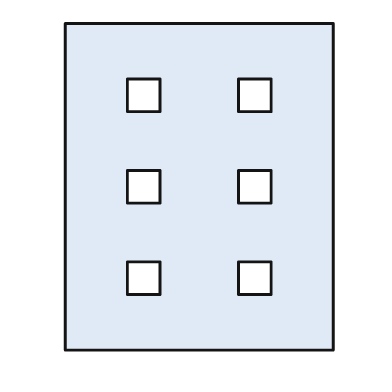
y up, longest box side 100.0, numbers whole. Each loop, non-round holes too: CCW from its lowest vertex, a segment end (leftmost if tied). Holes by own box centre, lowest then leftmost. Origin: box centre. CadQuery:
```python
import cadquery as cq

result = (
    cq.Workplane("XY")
    .moveTo(-41.0, -50.0)
    .lineTo(41.0, -50.0)
    .lineTo(41.0, 50.0)
    .lineTo(-41.0, 50.0)
    .close()
    .moveTo(-22.0, -33.0)
    .lineTo(-12.0, -33.0)
    .lineTo(-12.0, -23.0)
    .lineTo(-22.0, -23.0)
    .close()
    .moveTo(12.0, -33.0)
    .lineTo(22.0, -33.0)
    .lineTo(22.0, -23.0)
    .lineTo(12.0, -23.0)
    .close()
    .moveTo(-22.0, -5.0)
    .lineTo(-12.0, -5.0)
    .lineTo(-12.0, 5.0)
    .lineTo(-22.0, 5.0)
    .close()
    .moveTo(12.0, -5.0)
    .lineTo(22.0, -5.0)
    .lineTo(22.0, 5.0)
    .lineTo(12.0, 5.0)
    .close()
    .moveTo(-22.0, 23.0)
    .lineTo(-12.0, 23.0)
    .lineTo(-12.0, 33.0)
    .lineTo(-22.0, 33.0)
    .close()
    .moveTo(12.0, 23.0)
    .lineTo(22.0, 23.0)
    .lineTo(22.0, 33.0)
    .lineTo(12.0, 33.0)
    .close()
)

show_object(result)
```